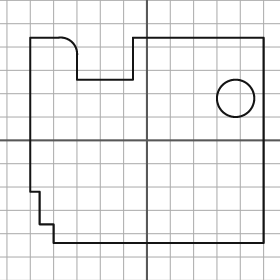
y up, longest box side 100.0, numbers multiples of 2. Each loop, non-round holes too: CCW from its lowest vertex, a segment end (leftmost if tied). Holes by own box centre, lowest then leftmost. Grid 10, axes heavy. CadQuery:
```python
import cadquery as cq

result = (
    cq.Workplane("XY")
    .moveTo(-40.0, -44.0)
    .lineTo(50.0, -44.0)
    .lineTo(50.0, 44.0)
    .lineTo(-6.0, 44.0)
    .lineTo(-6.0, 26.0)
    .lineTo(-30.0, 26.0)
    .lineTo(-30.0, 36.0)
    .threePointArc((-32.0, 42.0), (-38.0, 44.0))
    .lineTo(-50.0, 44.0)
    .lineTo(-50.0, -22.0)
    .lineTo(-46.0, -22.0)
    .lineTo(-46.0, -36.0)
    .lineTo(-40.0, -36.0)
    .close()
    .moveTo(38.0, 18.0)
    .circle(8.0)
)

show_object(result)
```